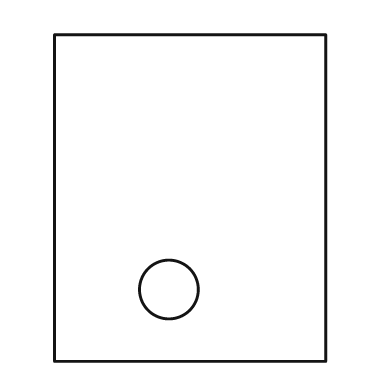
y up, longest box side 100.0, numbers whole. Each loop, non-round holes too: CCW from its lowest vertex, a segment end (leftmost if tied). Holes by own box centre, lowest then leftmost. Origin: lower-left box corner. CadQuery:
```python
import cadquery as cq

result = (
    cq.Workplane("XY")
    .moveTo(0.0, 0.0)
    .lineTo(83.0, 0.0)
    .lineTo(83.0, 100.0)
    .lineTo(0.0, 100.0)
    .close()
    .moveTo(35.0, 22.0)
    .circle(9.0)
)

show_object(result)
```